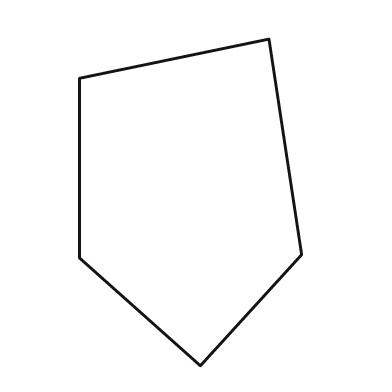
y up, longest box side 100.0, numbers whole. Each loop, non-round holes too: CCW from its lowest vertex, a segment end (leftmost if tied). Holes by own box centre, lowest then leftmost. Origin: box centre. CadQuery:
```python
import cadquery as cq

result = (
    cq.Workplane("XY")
    .moveTo(3.0, -50.0)
    .lineTo(34.0, -16.0)
    .lineTo(24.0, 50.0)
    .lineTo(-34.0, 38.0)
    .lineTo(-34.0, -17.0)
    .close()
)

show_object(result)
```